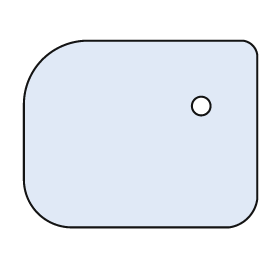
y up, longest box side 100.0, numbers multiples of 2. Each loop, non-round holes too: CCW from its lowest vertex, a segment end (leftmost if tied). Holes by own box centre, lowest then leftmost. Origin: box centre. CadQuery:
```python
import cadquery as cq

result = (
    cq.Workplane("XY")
    .moveTo(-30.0, -40.0)
    .lineTo(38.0, -40.0)
    .threePointArc((46.0, -36.0), (50.0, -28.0))
    .lineTo(50.0, 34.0)
    .threePointArc((48.0, 38.0), (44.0, 40.0))
    .lineTo(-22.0, 40.0)
    .threePointArc((-42.0, 32.0), (-50.0, 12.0))
    .lineTo(-50.0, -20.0)
    .threePointArc((-44.0, -34.0), (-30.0, -40.0))
    .close()
    .moveTo(26.0, 12.0)
    .circle(4.0)
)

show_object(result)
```